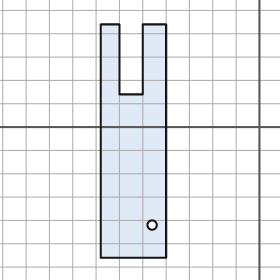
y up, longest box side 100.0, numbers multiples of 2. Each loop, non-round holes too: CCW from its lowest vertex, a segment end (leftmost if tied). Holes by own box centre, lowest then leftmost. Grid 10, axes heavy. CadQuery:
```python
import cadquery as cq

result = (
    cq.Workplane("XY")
    .moveTo(-68.0, -56.0)
    .lineTo(-40.0, -56.0)
    .lineTo(-40.0, 44.0)
    .lineTo(-50.0, 44.0)
    .lineTo(-50.0, 14.0)
    .lineTo(-60.0, 14.0)
    .lineTo(-60.0, 44.0)
    .lineTo(-68.0, 44.0)
    .close()
    .moveTo(-46.0, -42.0)
    .circle(2.0)
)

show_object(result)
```